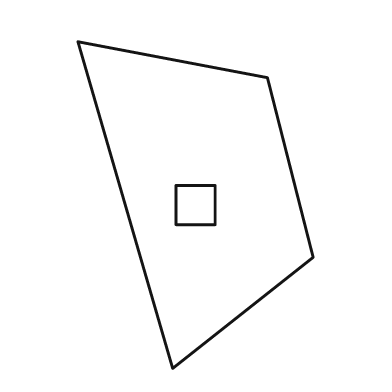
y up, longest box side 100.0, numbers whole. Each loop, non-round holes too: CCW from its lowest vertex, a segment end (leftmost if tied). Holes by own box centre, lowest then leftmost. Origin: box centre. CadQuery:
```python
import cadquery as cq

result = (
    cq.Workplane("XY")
    .moveTo(-7.0, -50.0)
    .lineTo(36.0, -16.0)
    .lineTo(22.0, 39.0)
    .lineTo(-36.0, 50.0)
    .close()
    .moveTo(-6.0, -6.0)
    .lineTo(6.0, -6.0)
    .lineTo(6.0, 6.0)
    .lineTo(-6.0, 6.0)
    .close()
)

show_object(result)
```